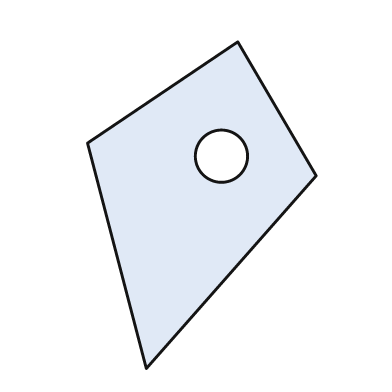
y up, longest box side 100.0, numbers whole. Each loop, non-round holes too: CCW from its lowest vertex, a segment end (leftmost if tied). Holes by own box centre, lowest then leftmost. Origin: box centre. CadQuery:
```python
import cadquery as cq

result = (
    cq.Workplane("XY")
    .moveTo(-17.0, -50.0)
    .lineTo(35.0, 9.0)
    .lineTo(11.0, 50.0)
    .lineTo(-35.0, 19.0)
    .close()
    .moveTo(6.0, 15.0)
    .circle(8.0)
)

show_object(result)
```